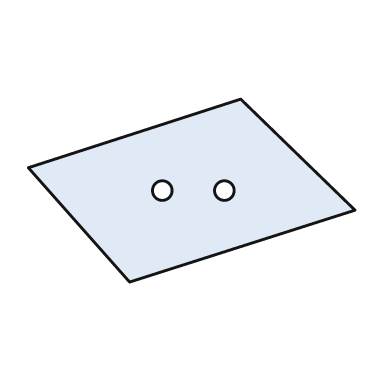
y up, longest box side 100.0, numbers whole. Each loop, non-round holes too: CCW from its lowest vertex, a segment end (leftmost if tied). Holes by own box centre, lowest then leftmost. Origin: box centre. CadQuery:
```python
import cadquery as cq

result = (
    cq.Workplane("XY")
    .moveTo(-19.0, -28.0)
    .lineTo(50.0, -6.0)
    .lineTo(15.0, 28.0)
    .lineTo(-50.0, 7.0)
    .close()
    .moveTo(-9.0, 0.0)
    .circle(3.0)
    .moveTo(10.0, 0.0)
    .circle(3.0)
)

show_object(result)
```